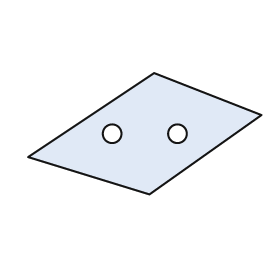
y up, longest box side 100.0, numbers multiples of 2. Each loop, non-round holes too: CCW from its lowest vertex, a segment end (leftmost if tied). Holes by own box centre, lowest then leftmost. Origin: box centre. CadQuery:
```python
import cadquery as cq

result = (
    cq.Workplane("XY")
    .moveTo(2.0, -26.0)
    .lineTo(50.0, 8.0)
    .lineTo(4.0, 26.0)
    .lineTo(-50.0, -10.0)
    .close()
    .moveTo(-14.0, 0.0)
    .circle(4.0)
    .moveTo(14.0, 0.0)
    .circle(4.0)
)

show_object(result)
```